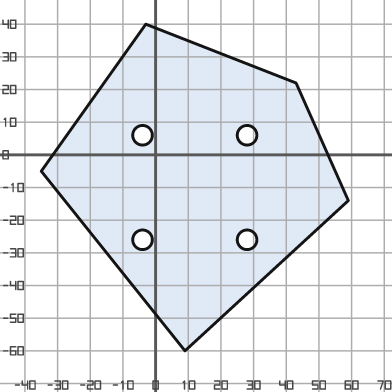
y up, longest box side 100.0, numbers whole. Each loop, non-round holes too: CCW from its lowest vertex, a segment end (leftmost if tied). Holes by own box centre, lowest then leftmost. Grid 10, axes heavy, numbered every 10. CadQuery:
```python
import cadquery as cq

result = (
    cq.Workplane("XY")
    .moveTo(9.0, -60.0)
    .lineTo(59.0, -14.0)
    .lineTo(43.0, 22.0)
    .lineTo(-3.0, 40.0)
    .lineTo(-35.0, -5.0)
    .close()
    .moveTo(-4.0, -26.0)
    .circle(3.0)
    .moveTo(28.0, -26.0)
    .circle(3.0)
    .moveTo(-4.0, 6.0)
    .circle(3.0)
    .moveTo(28.0, 6.0)
    .circle(3.0)
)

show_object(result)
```